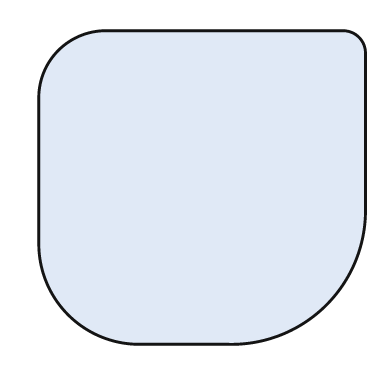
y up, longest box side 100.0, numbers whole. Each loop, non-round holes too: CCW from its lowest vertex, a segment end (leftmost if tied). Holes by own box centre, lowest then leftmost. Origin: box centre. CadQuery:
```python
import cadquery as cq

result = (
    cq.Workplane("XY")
    .moveTo(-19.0, -48.0)
    .lineTo(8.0, -48.0)
    .threePointArc((38.0, -36.0), (50.0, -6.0))
    .lineTo(50.0, 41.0)
    .threePointArc((48.0, 46.0), (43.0, 48.0))
    .lineTo(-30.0, 48.0)
    .threePointArc((-44.0, 42.0), (-50.0, 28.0))
    .lineTo(-50.0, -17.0)
    .threePointArc((-41.0, -39.0), (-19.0, -48.0))
    .close()
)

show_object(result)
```